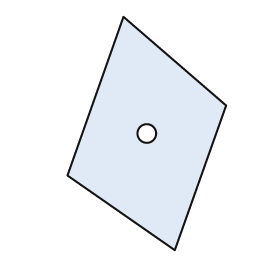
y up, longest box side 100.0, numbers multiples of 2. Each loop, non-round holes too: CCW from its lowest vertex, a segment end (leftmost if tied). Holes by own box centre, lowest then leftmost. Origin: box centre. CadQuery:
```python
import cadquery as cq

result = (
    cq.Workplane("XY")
    .moveTo(12.0, -50.0)
    .lineTo(34.0, 12.0)
    .lineTo(-10.0, 50.0)
    .lineTo(-34.0, -18.0)
    .close()
    .moveTo(0.0, 0.0)
    .circle(4.0)
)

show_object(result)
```